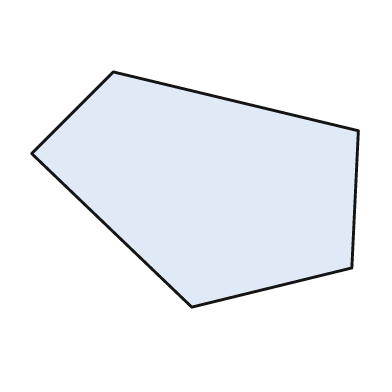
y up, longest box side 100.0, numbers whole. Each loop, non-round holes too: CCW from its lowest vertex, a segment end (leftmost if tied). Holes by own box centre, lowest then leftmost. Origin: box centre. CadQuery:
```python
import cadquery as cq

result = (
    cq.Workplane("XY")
    .moveTo(-1.0, -36.0)
    .lineTo(48.0, -24.0)
    .lineTo(50.0, 18.0)
    .lineTo(-25.0, 36.0)
    .lineTo(-50.0, 11.0)
    .close()
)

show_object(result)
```